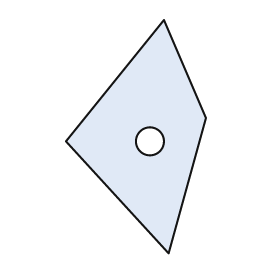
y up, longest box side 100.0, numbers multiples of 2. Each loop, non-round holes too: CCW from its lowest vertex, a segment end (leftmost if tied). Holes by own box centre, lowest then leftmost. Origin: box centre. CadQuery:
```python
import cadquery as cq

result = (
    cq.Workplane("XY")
    .moveTo(14.0, -50.0)
    .lineTo(30.0, 8.0)
    .lineTo(12.0, 50.0)
    .lineTo(-30.0, -2.0)
    .close()
    .moveTo(6.0, -2.0)
    .circle(6.0)
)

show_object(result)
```